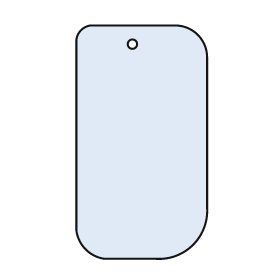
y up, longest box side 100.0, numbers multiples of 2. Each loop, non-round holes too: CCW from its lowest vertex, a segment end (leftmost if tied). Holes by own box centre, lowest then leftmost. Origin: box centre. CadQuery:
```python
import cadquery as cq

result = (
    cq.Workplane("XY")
    .moveTo(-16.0, -50.0)
    .lineTo(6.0, -50.0)
    .threePointArc((22.0, -44.0), (28.0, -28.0))
    .lineTo(28.0, 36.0)
    .threePointArc((24.0, 46.0), (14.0, 50.0))
    .lineTo(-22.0, 50.0)
    .threePointArc((-26.0, 48.0), (-28.0, 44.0))
    .lineTo(-28.0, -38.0)
    .threePointArc((-24.0, -46.0), (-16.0, -50.0))
    .close()
    .moveTo(-4.0, 42.0)
    .circle(2.0)
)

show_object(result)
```